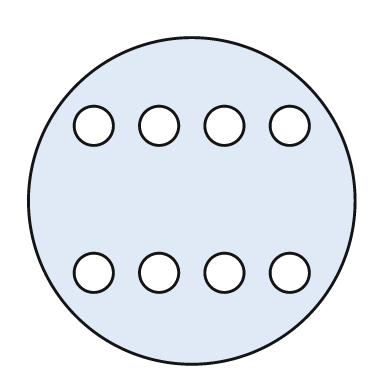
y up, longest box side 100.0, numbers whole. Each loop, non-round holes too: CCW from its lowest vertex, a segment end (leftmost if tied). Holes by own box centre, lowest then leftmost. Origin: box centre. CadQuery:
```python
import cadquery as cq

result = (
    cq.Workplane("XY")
    .moveTo(0.0, 0.0)
    .circle(50.0)
    .moveTo(-30.0, -22.0)
    .circle(6.0)
    .moveTo(-10.0, -22.0)
    .circle(6.0)
    .moveTo(10.0, -22.0)
    .circle(6.0)
    .moveTo(30.0, -22.0)
    .circle(6.0)
    .moveTo(-30.0, 23.0)
    .circle(6.0)
    .moveTo(-10.0, 23.0)
    .circle(6.0)
    .moveTo(10.0, 23.0)
    .circle(6.0)
    .moveTo(30.0, 23.0)
    .circle(6.0)
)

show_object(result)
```